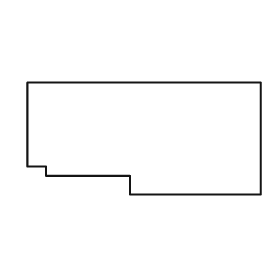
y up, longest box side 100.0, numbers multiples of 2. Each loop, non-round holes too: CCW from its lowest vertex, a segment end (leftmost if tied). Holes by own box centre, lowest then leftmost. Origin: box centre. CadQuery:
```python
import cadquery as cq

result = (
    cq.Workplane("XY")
    .moveTo(-6.0, -24.0)
    .lineTo(50.0, -24.0)
    .lineTo(50.0, 24.0)
    .lineTo(-50.0, 24.0)
    .lineTo(-50.0, -12.0)
    .lineTo(-42.0, -12.0)
    .lineTo(-42.0, -16.0)
    .lineTo(-6.0, -16.0)
    .close()
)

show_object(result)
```